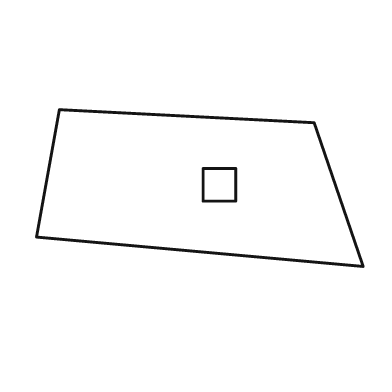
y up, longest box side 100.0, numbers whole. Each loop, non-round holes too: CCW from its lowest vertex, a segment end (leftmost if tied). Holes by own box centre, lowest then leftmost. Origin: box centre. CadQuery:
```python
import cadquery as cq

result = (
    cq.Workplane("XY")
    .moveTo(50.0, -24.0)
    .lineTo(35.0, 20.0)
    .lineTo(-43.0, 24.0)
    .lineTo(-50.0, -15.0)
    .close()
    .moveTo(1.0, -4.0)
    .lineTo(11.0, -4.0)
    .lineTo(11.0, 6.0)
    .lineTo(1.0, 6.0)
    .close()
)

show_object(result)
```